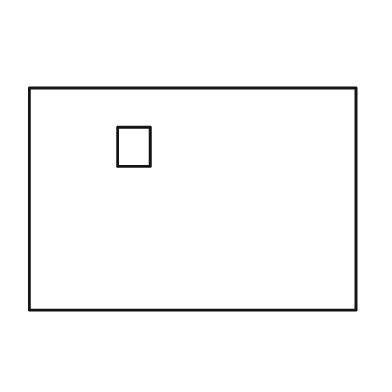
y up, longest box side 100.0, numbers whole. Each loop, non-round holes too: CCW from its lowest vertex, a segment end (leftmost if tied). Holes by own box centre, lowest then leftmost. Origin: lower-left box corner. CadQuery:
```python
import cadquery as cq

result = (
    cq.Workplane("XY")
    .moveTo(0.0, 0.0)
    .lineTo(100.0, 0.0)
    .lineTo(100.0, 68.0)
    .lineTo(0.0, 68.0)
    .close()
    .moveTo(27.0, 44.0)
    .lineTo(37.0, 44.0)
    .lineTo(37.0, 56.0)
    .lineTo(27.0, 56.0)
    .close()
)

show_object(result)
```